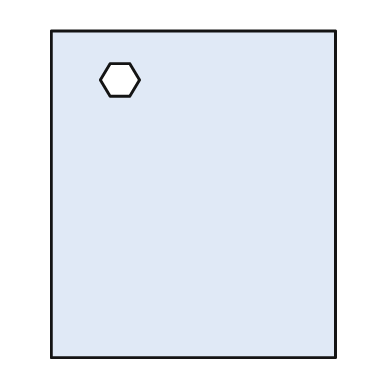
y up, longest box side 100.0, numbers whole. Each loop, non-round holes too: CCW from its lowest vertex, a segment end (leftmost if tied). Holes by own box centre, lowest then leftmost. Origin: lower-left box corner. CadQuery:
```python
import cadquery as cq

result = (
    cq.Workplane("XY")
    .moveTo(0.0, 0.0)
    .lineTo(87.0, 0.0)
    .lineTo(87.0, 100.0)
    .lineTo(0.0, 100.0)
    .close()
    .moveTo(18.0, 80.0)
    .lineTo(24.0, 80.0)
    .lineTo(27.0, 85.0)
    .lineTo(24.0, 90.0)
    .lineTo(18.0, 90.0)
    .lineTo(15.0, 85.0)
    .close()
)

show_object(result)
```